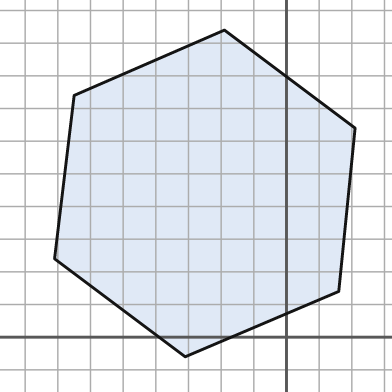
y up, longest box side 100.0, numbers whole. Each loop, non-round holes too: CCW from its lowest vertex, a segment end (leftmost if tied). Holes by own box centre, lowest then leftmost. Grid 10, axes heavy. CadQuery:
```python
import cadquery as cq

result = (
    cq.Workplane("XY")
    .moveTo(-31.0, -6.0)
    .lineTo(16.0, 14.0)
    .lineTo(21.0, 64.0)
    .lineTo(-19.0, 94.0)
    .lineTo(-65.0, 74.0)
    .lineTo(-71.0, 24.0)
    .close()
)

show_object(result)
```